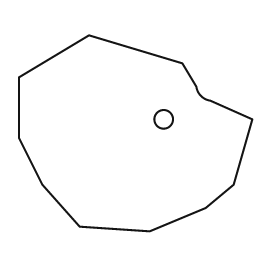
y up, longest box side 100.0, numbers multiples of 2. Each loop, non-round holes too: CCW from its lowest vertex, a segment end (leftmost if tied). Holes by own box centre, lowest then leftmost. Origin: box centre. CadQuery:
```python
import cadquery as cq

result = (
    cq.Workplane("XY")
    .moveTo(6.0, -42.0)
    .lineTo(30.0, -32.0)
    .lineTo(42.0, -22.0)
    .lineTo(50.0, 6.0)
    .lineTo(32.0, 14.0)
    .threePointArc((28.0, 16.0), (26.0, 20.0))
    .lineTo(20.0, 30.0)
    .lineTo(-20.0, 42.0)
    .lineTo(-50.0, 24.0)
    .lineTo(-50.0, -2.0)
    .lineTo(-40.0, -22.0)
    .lineTo(-24.0, -40.0)
    .close()
    .moveTo(12.0, 6.0)
    .circle(4.0)
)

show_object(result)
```